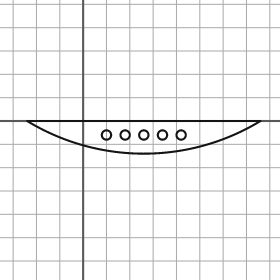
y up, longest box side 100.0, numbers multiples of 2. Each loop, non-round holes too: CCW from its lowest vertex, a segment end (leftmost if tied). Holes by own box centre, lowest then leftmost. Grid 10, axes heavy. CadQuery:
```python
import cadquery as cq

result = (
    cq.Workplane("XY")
    .moveTo(-24.0, 0.0)
    .threePointArc((26.0, -14.0), (76.0, 0.0))
    .close()
    .moveTo(10.0, -6.0)
    .circle(2.0)
    .moveTo(18.0, -6.0)
    .circle(2.0)
    .moveTo(26.0, -6.0)
    .circle(2.0)
    .moveTo(34.0, -6.0)
    .circle(2.0)
    .moveTo(42.0, -6.0)
    .circle(2.0)
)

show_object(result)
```